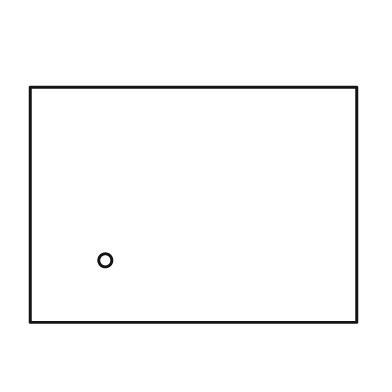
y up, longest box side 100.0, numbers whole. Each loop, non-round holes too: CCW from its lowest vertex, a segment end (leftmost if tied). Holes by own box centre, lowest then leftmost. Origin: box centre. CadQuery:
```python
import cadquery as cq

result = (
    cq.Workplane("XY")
    .moveTo(-50.0, -36.0)
    .lineTo(50.0, -36.0)
    .lineTo(50.0, 36.0)
    .lineTo(-50.0, 36.0)
    .close()
    .moveTo(-27.0, -17.0)
    .circle(2.0)
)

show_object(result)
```